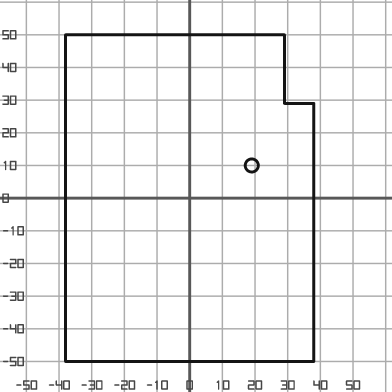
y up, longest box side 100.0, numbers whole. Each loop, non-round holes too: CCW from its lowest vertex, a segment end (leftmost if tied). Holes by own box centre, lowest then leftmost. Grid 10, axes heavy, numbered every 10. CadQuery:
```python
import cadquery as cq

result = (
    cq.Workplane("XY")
    .moveTo(-38.0, -50.0)
    .lineTo(38.0, -50.0)
    .lineTo(38.0, 29.0)
    .lineTo(29.0, 29.0)
    .lineTo(29.0, 50.0)
    .lineTo(-38.0, 50.0)
    .close()
    .moveTo(19.0, 10.0)
    .circle(2.0)
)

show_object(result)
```